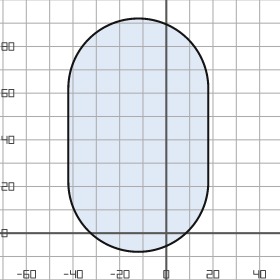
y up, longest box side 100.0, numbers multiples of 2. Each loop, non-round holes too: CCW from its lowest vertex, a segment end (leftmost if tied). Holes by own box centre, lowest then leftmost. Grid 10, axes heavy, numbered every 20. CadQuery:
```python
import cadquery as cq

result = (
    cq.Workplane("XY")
    .moveTo(-42.0, 22.0)
    .threePointArc((-12.0, -8.0), (18.0, 22.0))
    .lineTo(18.0, 62.0)
    .threePointArc((-12.0, 92.0), (-42.0, 62.0))
    .close()
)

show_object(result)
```